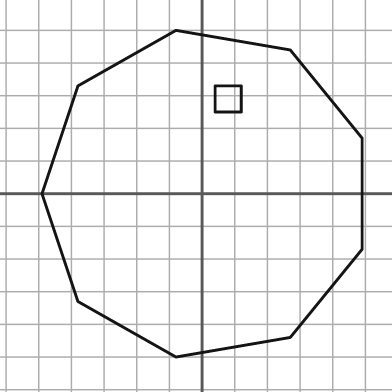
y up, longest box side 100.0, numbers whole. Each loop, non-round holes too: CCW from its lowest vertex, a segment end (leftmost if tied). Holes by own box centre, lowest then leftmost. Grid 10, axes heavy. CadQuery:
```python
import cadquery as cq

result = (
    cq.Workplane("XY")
    .moveTo(-8.0, -50.0)
    .lineTo(27.0, -44.0)
    .lineTo(49.0, -17.0)
    .lineTo(49.0, 17.0)
    .lineTo(27.0, 44.0)
    .lineTo(-8.0, 50.0)
    .lineTo(-38.0, 33.0)
    .lineTo(-49.0, 0.0)
    .lineTo(-38.0, -33.0)
    .close()
    .moveTo(4.0, 25.0)
    .lineTo(12.0, 25.0)
    .lineTo(12.0, 33.0)
    .lineTo(4.0, 33.0)
    .close()
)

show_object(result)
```